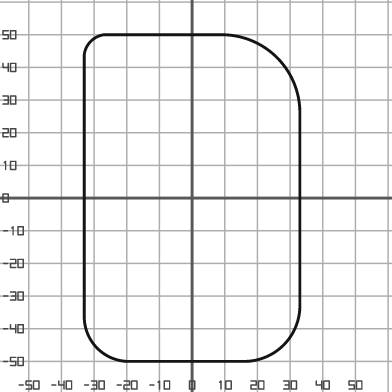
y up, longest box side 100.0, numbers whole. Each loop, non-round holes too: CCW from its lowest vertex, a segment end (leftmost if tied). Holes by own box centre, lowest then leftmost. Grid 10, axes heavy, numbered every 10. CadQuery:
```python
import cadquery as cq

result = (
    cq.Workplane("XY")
    .moveTo(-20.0, -50.0)
    .lineTo(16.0, -50.0)
    .threePointArc((28.0, -45.0), (33.0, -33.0))
    .lineTo(33.0, 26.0)
    .threePointArc((26.0, 43.0), (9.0, 50.0))
    .lineTo(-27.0, 50.0)
    .threePointArc((-31.0, 48.0), (-33.0, 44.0))
    .lineTo(-33.0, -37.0)
    .threePointArc((-29.0, -46.0), (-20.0, -50.0))
    .close()
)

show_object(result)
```